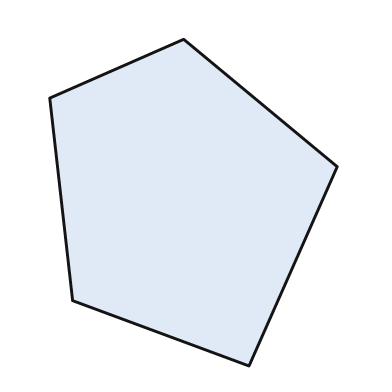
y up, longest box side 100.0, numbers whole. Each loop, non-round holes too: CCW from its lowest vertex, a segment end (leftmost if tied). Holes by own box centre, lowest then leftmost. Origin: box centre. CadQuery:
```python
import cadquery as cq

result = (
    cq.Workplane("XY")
    .moveTo(17.0, -50.0)
    .lineTo(44.0, 11.0)
    .lineTo(-3.0, 50.0)
    .lineTo(-44.0, 32.0)
    .lineTo(-37.0, -30.0)
    .close()
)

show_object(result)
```